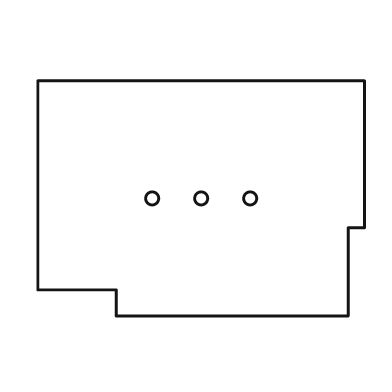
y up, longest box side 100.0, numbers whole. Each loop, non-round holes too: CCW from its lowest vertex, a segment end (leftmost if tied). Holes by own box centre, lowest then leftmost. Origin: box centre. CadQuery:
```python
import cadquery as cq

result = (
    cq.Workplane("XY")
    .moveTo(-26.0, -36.0)
    .lineTo(45.0, -36.0)
    .lineTo(45.0, -9.0)
    .lineTo(50.0, -9.0)
    .lineTo(50.0, 36.0)
    .lineTo(-50.0, 36.0)
    .lineTo(-50.0, -28.0)
    .lineTo(-26.0, -28.0)
    .close()
    .moveTo(-15.0, 0.0)
    .circle(2.0)
    .moveTo(0.0, 0.0)
    .circle(2.0)
    .moveTo(15.0, 0.0)
    .circle(2.0)
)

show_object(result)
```